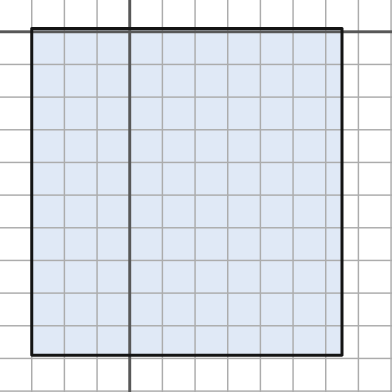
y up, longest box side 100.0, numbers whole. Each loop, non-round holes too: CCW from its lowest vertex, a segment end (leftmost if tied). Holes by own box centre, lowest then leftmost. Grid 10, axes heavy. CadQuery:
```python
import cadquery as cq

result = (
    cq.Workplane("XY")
    .moveTo(-30.0, -99.0)
    .lineTo(65.0, -99.0)
    .lineTo(65.0, 1.0)
    .lineTo(-30.0, 1.0)
    .close()
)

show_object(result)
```